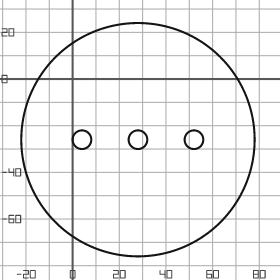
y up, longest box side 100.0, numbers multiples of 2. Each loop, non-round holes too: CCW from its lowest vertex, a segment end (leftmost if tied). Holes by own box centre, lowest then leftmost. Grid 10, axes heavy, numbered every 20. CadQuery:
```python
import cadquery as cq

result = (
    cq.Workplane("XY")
    .moveTo(28.0, -26.0)
    .circle(50.0)
    .moveTo(4.0, -26.0)
    .circle(4.0)
    .moveTo(28.0, -26.0)
    .circle(4.0)
    .moveTo(52.0, -26.0)
    .circle(4.0)
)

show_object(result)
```